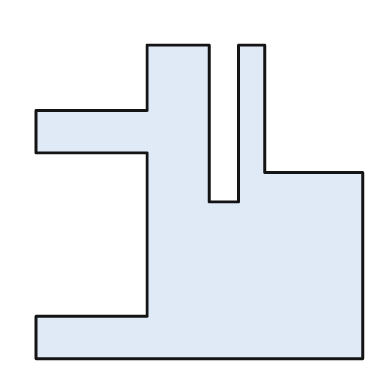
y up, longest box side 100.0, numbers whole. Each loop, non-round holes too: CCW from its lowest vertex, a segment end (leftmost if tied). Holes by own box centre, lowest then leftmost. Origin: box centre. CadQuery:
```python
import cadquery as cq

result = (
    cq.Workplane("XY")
    .moveTo(-50.0, -48.0)
    .lineTo(50.0, -48.0)
    .lineTo(50.0, 9.0)
    .lineTo(20.0, 9.0)
    .lineTo(20.0, 48.0)
    .lineTo(12.0, 48.0)
    .lineTo(12.0, 0.0)
    .lineTo(3.0, 0.0)
    .lineTo(3.0, 48.0)
    .lineTo(-16.0, 48.0)
    .lineTo(-16.0, 28.0)
    .lineTo(-50.0, 28.0)
    .lineTo(-50.0, 15.0)
    .lineTo(-16.0, 15.0)
    .lineTo(-16.0, -35.0)
    .lineTo(-50.0, -35.0)
    .close()
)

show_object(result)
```